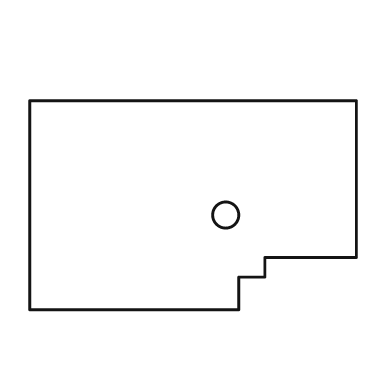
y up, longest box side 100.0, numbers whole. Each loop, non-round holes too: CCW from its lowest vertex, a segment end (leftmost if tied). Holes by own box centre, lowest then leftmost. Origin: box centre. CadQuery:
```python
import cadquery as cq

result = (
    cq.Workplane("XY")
    .moveTo(-50.0, -32.0)
    .lineTo(14.0, -32.0)
    .lineTo(14.0, -22.0)
    .lineTo(22.0, -22.0)
    .lineTo(22.0, -16.0)
    .lineTo(50.0, -16.0)
    .lineTo(50.0, 32.0)
    .lineTo(-50.0, 32.0)
    .close()
    .moveTo(10.0, -3.0)
    .circle(4.0)
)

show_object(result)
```